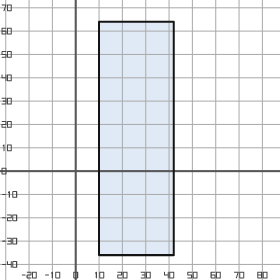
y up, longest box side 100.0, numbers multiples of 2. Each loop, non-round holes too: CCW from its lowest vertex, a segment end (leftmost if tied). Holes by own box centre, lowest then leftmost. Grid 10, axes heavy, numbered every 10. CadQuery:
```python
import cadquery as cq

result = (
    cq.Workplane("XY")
    .moveTo(10.0, -36.0)
    .lineTo(42.0, -36.0)
    .lineTo(42.0, 64.0)
    .lineTo(10.0, 64.0)
    .close()
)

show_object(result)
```